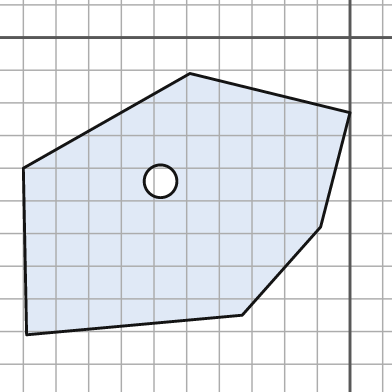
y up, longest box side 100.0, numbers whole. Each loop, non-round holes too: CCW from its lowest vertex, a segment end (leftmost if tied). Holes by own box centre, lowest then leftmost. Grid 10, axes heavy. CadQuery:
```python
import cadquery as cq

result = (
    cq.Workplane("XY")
    .moveTo(-99.0, -91.0)
    .lineTo(-33.0, -85.0)
    .lineTo(-9.0, -58.0)
    .lineTo(0.0, -23.0)
    .lineTo(-49.0, -11.0)
    .lineTo(-100.0, -40.0)
    .close()
    .moveTo(-58.0, -44.0)
    .circle(5.0)
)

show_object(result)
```